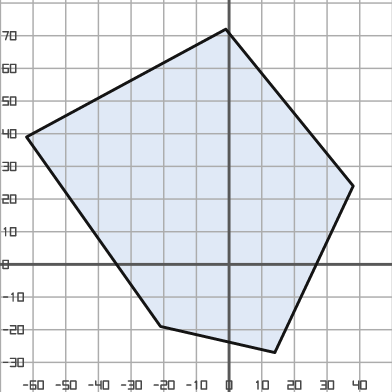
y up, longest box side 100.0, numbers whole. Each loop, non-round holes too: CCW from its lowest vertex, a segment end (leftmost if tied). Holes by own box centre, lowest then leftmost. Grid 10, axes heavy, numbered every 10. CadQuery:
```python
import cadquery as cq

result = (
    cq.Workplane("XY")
    .moveTo(14.0, -27.0)
    .lineTo(38.0, 24.0)
    .lineTo(-1.0, 72.0)
    .lineTo(-62.0, 39.0)
    .lineTo(-21.0, -19.0)
    .close()
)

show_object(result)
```